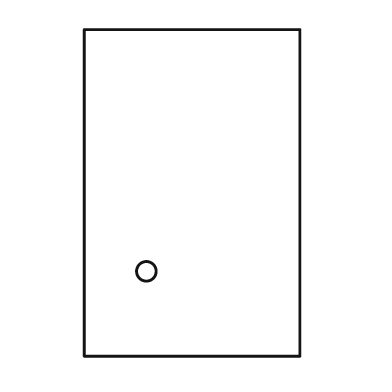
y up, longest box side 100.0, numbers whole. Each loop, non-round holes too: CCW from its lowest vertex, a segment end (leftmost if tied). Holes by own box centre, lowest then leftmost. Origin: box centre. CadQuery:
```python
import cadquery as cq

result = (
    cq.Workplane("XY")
    .moveTo(-33.0, -50.0)
    .lineTo(33.0, -50.0)
    .lineTo(33.0, 50.0)
    .lineTo(-33.0, 50.0)
    .close()
    .moveTo(-14.0, -24.0)
    .circle(3.0)
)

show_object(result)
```